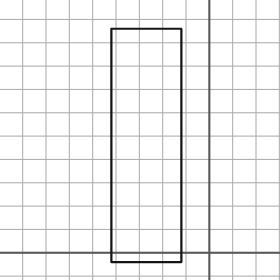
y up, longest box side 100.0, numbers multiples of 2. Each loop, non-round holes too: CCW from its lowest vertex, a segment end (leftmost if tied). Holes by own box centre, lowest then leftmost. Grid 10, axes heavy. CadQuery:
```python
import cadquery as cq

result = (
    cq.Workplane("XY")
    .moveTo(-42.0, -4.0)
    .lineTo(-12.0, -4.0)
    .lineTo(-12.0, 96.0)
    .lineTo(-42.0, 96.0)
    .close()
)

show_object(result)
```